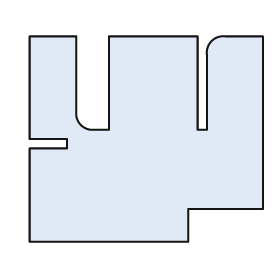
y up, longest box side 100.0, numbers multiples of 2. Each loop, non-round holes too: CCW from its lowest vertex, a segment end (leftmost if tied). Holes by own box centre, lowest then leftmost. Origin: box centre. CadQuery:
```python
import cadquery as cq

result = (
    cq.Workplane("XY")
    .moveTo(-50.0, -44.0)
    .lineTo(18.0, -44.0)
    .lineTo(18.0, -30.0)
    .lineTo(50.0, -30.0)
    .lineTo(50.0, 44.0)
    .lineTo(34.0, 44.0)
    .threePointArc((28.0, 42.0), (26.0, 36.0))
    .lineTo(26.0, 4.0)
    .lineTo(22.0, 4.0)
    .lineTo(22.0, 44.0)
    .lineTo(-16.0, 44.0)
    .lineTo(-16.0, 4.0)
    .lineTo(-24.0, 4.0)
    .threePointArc((-28.0, 6.0), (-30.0, 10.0))
    .lineTo(-30.0, 44.0)
    .lineTo(-50.0, 44.0)
    .lineTo(-50.0, 0.0)
    .lineTo(-34.0, 0.0)
    .lineTo(-34.0, -4.0)
    .lineTo(-50.0, -4.0)
    .close()
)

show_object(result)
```